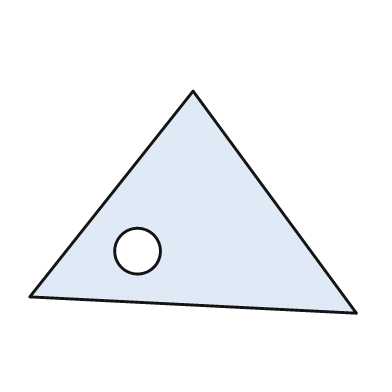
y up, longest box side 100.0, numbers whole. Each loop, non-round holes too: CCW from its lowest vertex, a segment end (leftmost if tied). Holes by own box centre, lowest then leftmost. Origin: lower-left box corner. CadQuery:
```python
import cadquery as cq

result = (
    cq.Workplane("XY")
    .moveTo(100.0, 0.0)
    .lineTo(50.0, 68.0)
    .lineTo(0.0, 5.0)
    .close()
    .moveTo(33.0, 19.0)
    .circle(7.0)
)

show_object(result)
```